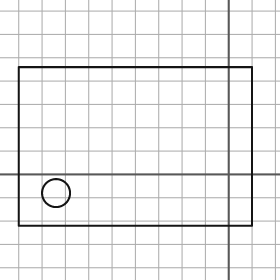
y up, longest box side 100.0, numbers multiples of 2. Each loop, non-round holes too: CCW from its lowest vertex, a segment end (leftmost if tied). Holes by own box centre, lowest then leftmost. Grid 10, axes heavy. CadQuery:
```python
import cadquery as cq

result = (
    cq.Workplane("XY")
    .moveTo(-90.0, -22.0)
    .lineTo(10.0, -22.0)
    .lineTo(10.0, 46.0)
    .lineTo(-90.0, 46.0)
    .close()
    .moveTo(-74.0, -8.0)
    .circle(6.0)
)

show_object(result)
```